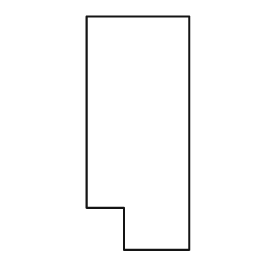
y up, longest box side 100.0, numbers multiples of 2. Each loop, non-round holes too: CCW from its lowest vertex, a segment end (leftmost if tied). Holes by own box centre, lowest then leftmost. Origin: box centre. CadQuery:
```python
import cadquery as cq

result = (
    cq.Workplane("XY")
    .moveTo(-6.0, -50.0)
    .lineTo(22.0, -50.0)
    .lineTo(22.0, 50.0)
    .lineTo(-22.0, 50.0)
    .lineTo(-22.0, -32.0)
    .lineTo(-6.0, -32.0)
    .close()
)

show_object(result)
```